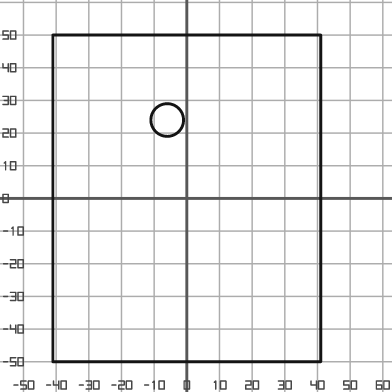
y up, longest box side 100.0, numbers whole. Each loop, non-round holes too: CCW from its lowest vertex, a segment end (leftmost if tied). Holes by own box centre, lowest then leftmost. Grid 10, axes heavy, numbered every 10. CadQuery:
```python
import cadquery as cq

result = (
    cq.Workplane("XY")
    .moveTo(-41.0, -50.0)
    .lineTo(41.0, -50.0)
    .lineTo(41.0, 50.0)
    .lineTo(-41.0, 50.0)
    .close()
    .moveTo(-6.0, 24.0)
    .circle(5.0)
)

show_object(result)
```